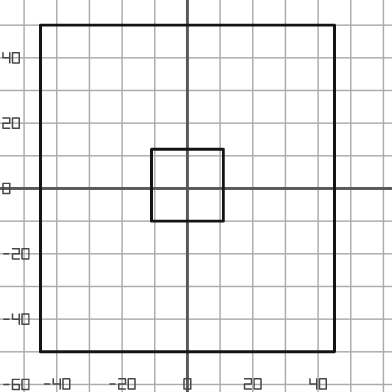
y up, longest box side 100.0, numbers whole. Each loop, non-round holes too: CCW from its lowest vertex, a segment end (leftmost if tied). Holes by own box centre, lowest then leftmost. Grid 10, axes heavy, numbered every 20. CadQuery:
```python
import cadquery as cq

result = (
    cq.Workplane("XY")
    .moveTo(-45.0, -50.0)
    .lineTo(45.0, -50.0)
    .lineTo(45.0, 50.0)
    .lineTo(-45.0, 50.0)
    .close()
    .moveTo(-11.0, -10.0)
    .lineTo(11.0, -10.0)
    .lineTo(11.0, 12.0)
    .lineTo(-11.0, 12.0)
    .close()
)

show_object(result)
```